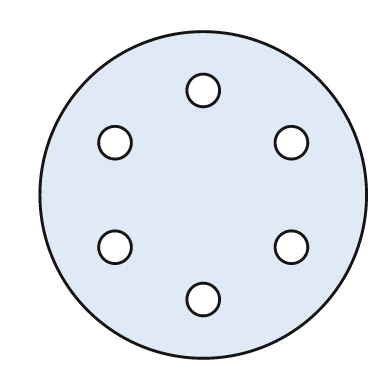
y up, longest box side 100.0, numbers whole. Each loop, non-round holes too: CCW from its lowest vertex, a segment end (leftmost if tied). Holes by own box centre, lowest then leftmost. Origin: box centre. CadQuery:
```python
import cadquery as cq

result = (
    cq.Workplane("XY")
    .moveTo(0.0, 0.0)
    .circle(50.0)
    .moveTo(0.0, -32.0)
    .circle(5.0)
    .moveTo(-27.0, -16.0)
    .circle(5.0)
    .moveTo(27.0, -16.0)
    .circle(5.0)
    .moveTo(-27.0, 16.0)
    .circle(5.0)
    .moveTo(27.0, 16.0)
    .circle(5.0)
    .moveTo(0.0, 32.0)
    .circle(5.0)
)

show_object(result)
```